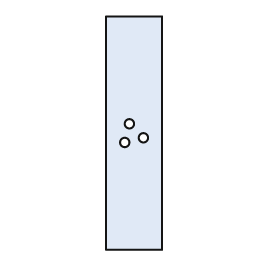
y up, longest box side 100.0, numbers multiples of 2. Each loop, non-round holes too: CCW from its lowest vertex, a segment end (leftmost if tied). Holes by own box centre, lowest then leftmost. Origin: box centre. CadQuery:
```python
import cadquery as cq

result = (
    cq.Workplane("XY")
    .moveTo(-12.0, -50.0)
    .lineTo(12.0, -50.0)
    .lineTo(12.0, 50.0)
    .lineTo(-12.0, 50.0)
    .close()
    .moveTo(-4.0, -4.0)
    .circle(2.0)
    .moveTo(4.0, -2.0)
    .circle(2.0)
    .moveTo(-2.0, 4.0)
    .circle(2.0)
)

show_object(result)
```